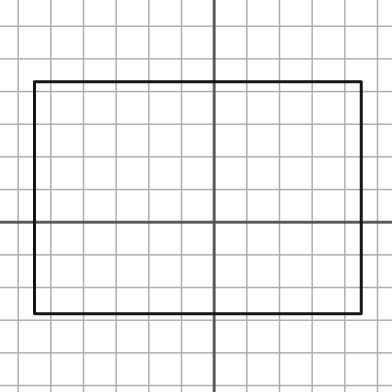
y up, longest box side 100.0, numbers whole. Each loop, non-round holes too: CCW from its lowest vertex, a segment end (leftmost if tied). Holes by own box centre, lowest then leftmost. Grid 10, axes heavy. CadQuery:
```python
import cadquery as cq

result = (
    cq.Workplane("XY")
    .moveTo(-55.0, -28.0)
    .lineTo(45.0, -28.0)
    .lineTo(45.0, 43.0)
    .lineTo(-55.0, 43.0)
    .close()
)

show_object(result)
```